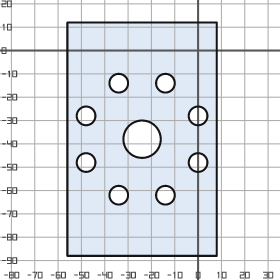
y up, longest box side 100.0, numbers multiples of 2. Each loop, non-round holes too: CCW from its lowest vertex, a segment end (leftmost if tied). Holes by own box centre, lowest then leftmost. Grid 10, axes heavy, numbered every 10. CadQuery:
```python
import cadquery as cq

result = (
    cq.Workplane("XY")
    .moveTo(-56.0, -88.0)
    .lineTo(8.0, -88.0)
    .lineTo(8.0, 12.0)
    .lineTo(-56.0, 12.0)
    .close()
    .moveTo(-34.0, -62.0)
    .circle(4.0)
    .moveTo(-14.0, -62.0)
    .circle(4.0)
    .moveTo(-48.0, -48.0)
    .circle(4.0)
    .moveTo(0.0, -48.0)
    .circle(4.0)
    .moveTo(-24.0, -38.0)
    .circle(8.0)
    .moveTo(-48.0, -28.0)
    .circle(4.0)
    .moveTo(0.0, -28.0)
    .circle(4.0)
    .moveTo(-34.0, -14.0)
    .circle(4.0)
    .moveTo(-14.0, -14.0)
    .circle(4.0)
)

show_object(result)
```